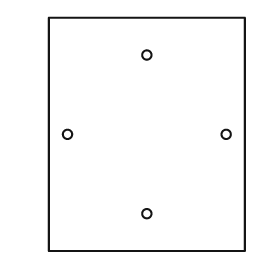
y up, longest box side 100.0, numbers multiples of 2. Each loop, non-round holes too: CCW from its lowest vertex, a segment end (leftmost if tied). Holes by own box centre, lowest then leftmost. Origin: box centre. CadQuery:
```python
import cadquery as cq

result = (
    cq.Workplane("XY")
    .moveTo(-42.0, -50.0)
    .lineTo(42.0, -50.0)
    .lineTo(42.0, 50.0)
    .lineTo(-42.0, 50.0)
    .close()
    .moveTo(0.0, -34.0)
    .circle(2.0)
    .moveTo(-34.0, 0.0)
    .circle(2.0)
    .moveTo(34.0, 0.0)
    .circle(2.0)
    .moveTo(0.0, 34.0)
    .circle(2.0)
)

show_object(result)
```